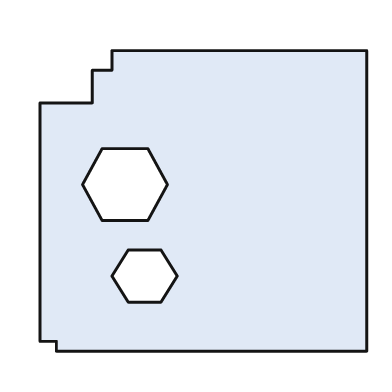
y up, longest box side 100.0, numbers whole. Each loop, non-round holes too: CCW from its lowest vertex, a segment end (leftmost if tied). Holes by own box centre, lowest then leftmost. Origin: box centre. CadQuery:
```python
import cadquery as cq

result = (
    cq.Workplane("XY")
    .moveTo(-45.0, -46.0)
    .lineTo(50.0, -46.0)
    .lineTo(50.0, 46.0)
    .lineTo(-28.0, 46.0)
    .lineTo(-28.0, 40.0)
    .lineTo(-34.0, 40.0)
    .lineTo(-34.0, 30.0)
    .lineTo(-50.0, 30.0)
    .lineTo(-50.0, -43.0)
    .lineTo(-45.0, -43.0)
    .close()
    .moveTo(-23.0, -31.0)
    .lineTo(-13.0, -31.0)
    .lineTo(-8.0, -23.0)
    .lineTo(-13.0, -15.0)
    .lineTo(-23.0, -15.0)
    .lineTo(-28.0, -23.0)
    .close()
    .moveTo(-31.0, -6.0)
    .lineTo(-17.0, -6.0)
    .lineTo(-11.0, 5.0)
    .lineTo(-17.0, 16.0)
    .lineTo(-31.0, 16.0)
    .lineTo(-37.0, 5.0)
    .close()
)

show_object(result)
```